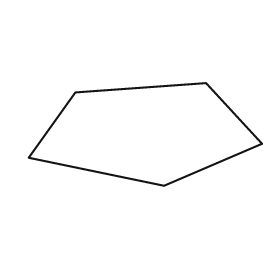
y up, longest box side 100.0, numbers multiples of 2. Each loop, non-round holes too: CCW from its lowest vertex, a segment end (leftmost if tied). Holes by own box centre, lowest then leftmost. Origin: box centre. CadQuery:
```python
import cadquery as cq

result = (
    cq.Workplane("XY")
    .moveTo(8.0, -22.0)
    .lineTo(50.0, -4.0)
    .lineTo(26.0, 22.0)
    .lineTo(-30.0, 18.0)
    .lineTo(-50.0, -10.0)
    .close()
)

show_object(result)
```